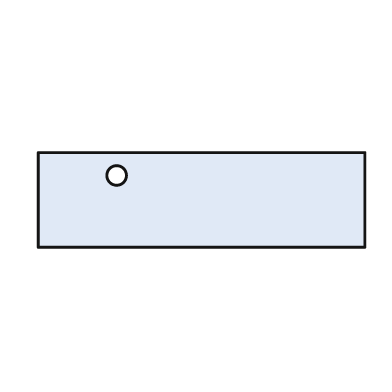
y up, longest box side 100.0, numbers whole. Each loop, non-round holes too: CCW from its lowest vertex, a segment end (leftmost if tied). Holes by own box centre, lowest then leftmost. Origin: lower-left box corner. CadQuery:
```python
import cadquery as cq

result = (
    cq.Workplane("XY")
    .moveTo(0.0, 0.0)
    .lineTo(100.0, 0.0)
    .lineTo(100.0, 29.0)
    .lineTo(0.0, 29.0)
    .close()
    .moveTo(24.0, 22.0)
    .circle(3.0)
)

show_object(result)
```